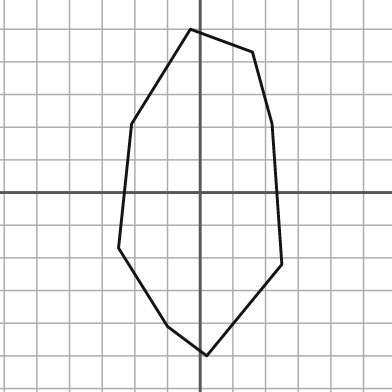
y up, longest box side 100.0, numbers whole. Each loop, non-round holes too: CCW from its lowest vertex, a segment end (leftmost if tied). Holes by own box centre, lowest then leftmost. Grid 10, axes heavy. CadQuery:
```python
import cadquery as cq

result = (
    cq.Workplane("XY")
    .moveTo(2.0, -50.0)
    .lineTo(25.0, -22.0)
    .lineTo(22.0, 21.0)
    .lineTo(16.0, 43.0)
    .lineTo(-3.0, 50.0)
    .lineTo(-21.0, 21.0)
    .lineTo(-25.0, -17.0)
    .lineTo(-10.0, -41.0)
    .close()
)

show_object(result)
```